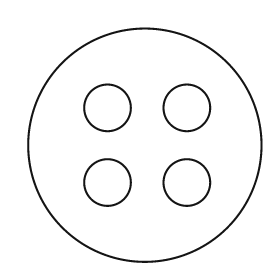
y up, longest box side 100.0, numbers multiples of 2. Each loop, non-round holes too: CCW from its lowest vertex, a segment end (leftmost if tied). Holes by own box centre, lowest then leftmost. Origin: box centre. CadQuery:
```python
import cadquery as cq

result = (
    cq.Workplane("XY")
    .moveTo(0.0, 0.0)
    .circle(50.0)
    .moveTo(-16.0, -16.0)
    .circle(10.0)
    .moveTo(18.0, -16.0)
    .circle(10.0)
    .moveTo(-16.0, 16.0)
    .circle(10.0)
    .moveTo(18.0, 16.0)
    .circle(10.0)
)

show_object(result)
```